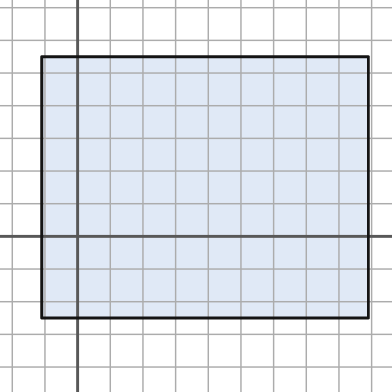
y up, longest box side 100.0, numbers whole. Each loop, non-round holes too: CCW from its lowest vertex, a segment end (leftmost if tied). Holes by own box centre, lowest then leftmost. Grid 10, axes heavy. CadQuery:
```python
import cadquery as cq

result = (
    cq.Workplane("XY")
    .moveTo(-11.0, -25.0)
    .lineTo(89.0, -25.0)
    .lineTo(89.0, 55.0)
    .lineTo(-11.0, 55.0)
    .close()
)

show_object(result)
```